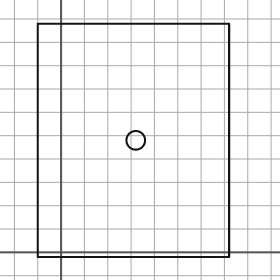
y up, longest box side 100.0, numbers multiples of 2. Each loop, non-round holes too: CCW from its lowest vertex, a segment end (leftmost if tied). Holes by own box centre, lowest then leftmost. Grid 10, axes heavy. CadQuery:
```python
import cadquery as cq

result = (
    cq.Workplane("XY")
    .moveTo(-10.0, -2.0)
    .lineTo(72.0, -2.0)
    .lineTo(72.0, 98.0)
    .lineTo(-10.0, 98.0)
    .close()
    .moveTo(32.0, 48.0)
    .circle(4.0)
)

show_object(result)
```